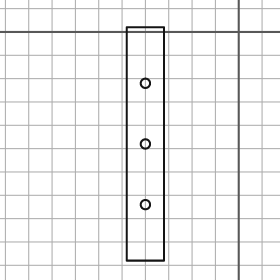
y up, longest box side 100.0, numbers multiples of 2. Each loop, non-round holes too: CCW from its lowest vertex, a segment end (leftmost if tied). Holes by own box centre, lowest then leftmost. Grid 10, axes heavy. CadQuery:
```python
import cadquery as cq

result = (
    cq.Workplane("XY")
    .moveTo(-48.0, -98.0)
    .lineTo(-32.0, -98.0)
    .lineTo(-32.0, 2.0)
    .lineTo(-48.0, 2.0)
    .close()
    .moveTo(-40.0, -74.0)
    .circle(2.0)
    .moveTo(-40.0, -48.0)
    .circle(2.0)
    .moveTo(-40.0, -22.0)
    .circle(2.0)
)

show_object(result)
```